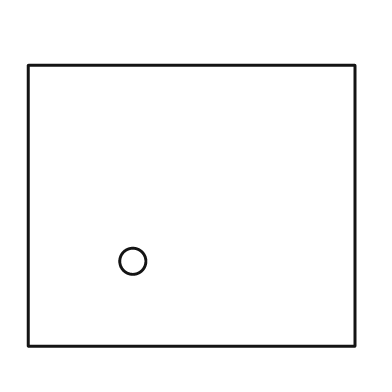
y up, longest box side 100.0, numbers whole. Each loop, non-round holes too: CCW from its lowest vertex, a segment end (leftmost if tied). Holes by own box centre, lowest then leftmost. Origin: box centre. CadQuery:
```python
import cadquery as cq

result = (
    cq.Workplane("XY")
    .moveTo(-50.0, -43.0)
    .lineTo(50.0, -43.0)
    .lineTo(50.0, 43.0)
    .lineTo(-50.0, 43.0)
    .close()
    .moveTo(-18.0, -17.0)
    .circle(4.0)
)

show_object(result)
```